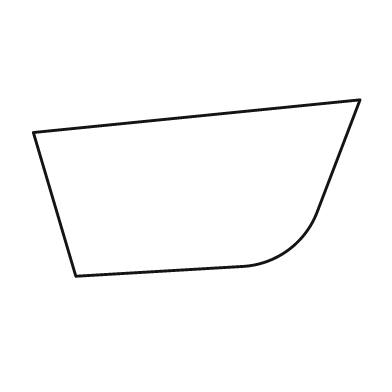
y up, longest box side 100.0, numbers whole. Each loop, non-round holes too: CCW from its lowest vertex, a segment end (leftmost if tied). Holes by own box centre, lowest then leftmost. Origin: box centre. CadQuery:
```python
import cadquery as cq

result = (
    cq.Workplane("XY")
    .moveTo(-37.0, -27.0)
    .lineTo(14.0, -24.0)
    .threePointArc((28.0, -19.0), (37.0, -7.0))
    .lineTo(50.0, 27.0)
    .lineTo(-50.0, 17.0)
    .close()
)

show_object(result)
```